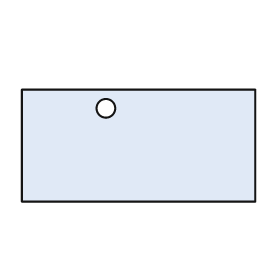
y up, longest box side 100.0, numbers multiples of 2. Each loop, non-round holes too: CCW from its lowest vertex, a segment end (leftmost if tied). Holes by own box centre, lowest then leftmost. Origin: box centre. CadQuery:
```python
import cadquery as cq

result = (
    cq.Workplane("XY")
    .moveTo(-50.0, -24.0)
    .lineTo(50.0, -24.0)
    .lineTo(50.0, 24.0)
    .lineTo(-50.0, 24.0)
    .close()
    .moveTo(-14.0, 16.0)
    .circle(4.0)
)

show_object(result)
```